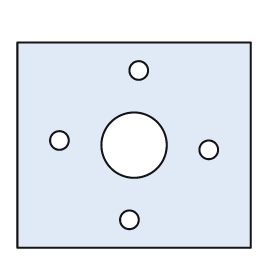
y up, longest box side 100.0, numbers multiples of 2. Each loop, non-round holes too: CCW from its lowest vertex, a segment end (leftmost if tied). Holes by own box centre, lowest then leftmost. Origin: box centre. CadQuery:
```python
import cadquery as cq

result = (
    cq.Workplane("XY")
    .moveTo(-50.0, -44.0)
    .lineTo(50.0, -44.0)
    .lineTo(50.0, 44.0)
    .lineTo(-50.0, 44.0)
    .close()
    .moveTo(-2.0, -32.0)
    .circle(4.0)
    .moveTo(32.0, -2.0)
    .circle(4.0)
    .moveTo(0.0, 0.0)
    .circle(14.0)
    .moveTo(-32.0, 2.0)
    .circle(4.0)
    .moveTo(2.0, 32.0)
    .circle(4.0)
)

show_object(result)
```